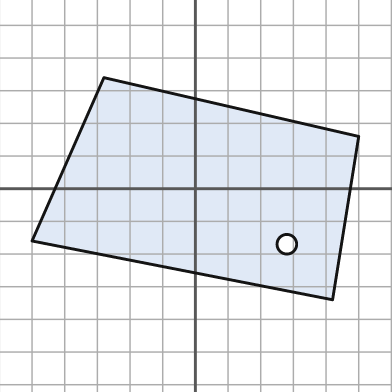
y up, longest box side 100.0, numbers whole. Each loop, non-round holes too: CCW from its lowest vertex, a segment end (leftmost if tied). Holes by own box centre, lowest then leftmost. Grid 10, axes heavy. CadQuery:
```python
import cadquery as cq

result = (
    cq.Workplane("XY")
    .moveTo(42.0, -34.0)
    .lineTo(50.0, 16.0)
    .lineTo(-28.0, 34.0)
    .lineTo(-50.0, -16.0)
    .close()
    .moveTo(28.0, -17.0)
    .circle(3.0)
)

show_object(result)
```